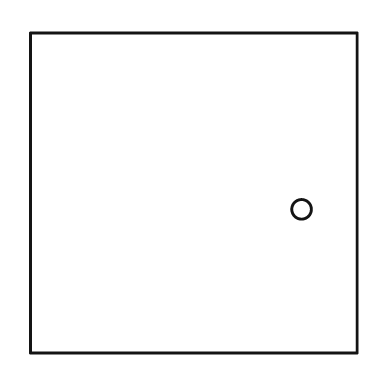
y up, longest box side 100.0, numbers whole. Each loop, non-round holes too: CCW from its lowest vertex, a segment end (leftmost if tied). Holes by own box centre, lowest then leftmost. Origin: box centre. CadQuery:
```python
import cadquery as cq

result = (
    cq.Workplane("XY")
    .moveTo(-50.0, -49.0)
    .lineTo(50.0, -49.0)
    .lineTo(50.0, 49.0)
    .lineTo(-50.0, 49.0)
    .close()
    .moveTo(33.0, -5.0)
    .circle(3.0)
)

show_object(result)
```